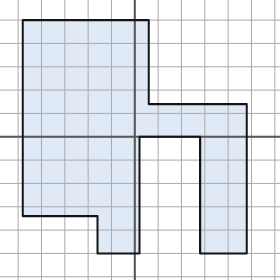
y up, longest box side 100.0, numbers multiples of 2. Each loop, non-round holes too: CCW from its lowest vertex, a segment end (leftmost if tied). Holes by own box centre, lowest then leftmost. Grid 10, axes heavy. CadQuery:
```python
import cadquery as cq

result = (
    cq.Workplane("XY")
    .moveTo(-16.0, -50.0)
    .lineTo(2.0, -50.0)
    .lineTo(2.0, 0.0)
    .lineTo(28.0, 0.0)
    .lineTo(28.0, -50.0)
    .lineTo(48.0, -50.0)
    .lineTo(48.0, 14.0)
    .lineTo(6.0, 14.0)
    .lineTo(6.0, 50.0)
    .lineTo(-48.0, 50.0)
    .lineTo(-48.0, -34.0)
    .lineTo(-16.0, -34.0)
    .close()
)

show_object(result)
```